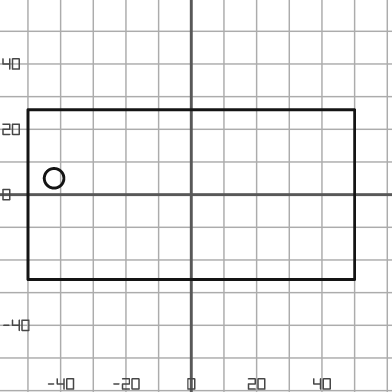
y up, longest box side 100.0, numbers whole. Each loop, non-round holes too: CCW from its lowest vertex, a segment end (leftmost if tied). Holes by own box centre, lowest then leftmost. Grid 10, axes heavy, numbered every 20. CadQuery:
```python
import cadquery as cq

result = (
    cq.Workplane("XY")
    .moveTo(-50.0, -26.0)
    .lineTo(50.0, -26.0)
    .lineTo(50.0, 26.0)
    .lineTo(-50.0, 26.0)
    .close()
    .moveTo(-42.0, 5.0)
    .circle(3.0)
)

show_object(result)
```